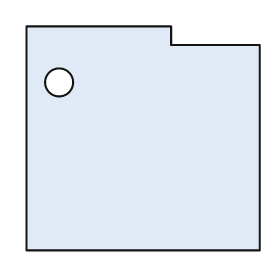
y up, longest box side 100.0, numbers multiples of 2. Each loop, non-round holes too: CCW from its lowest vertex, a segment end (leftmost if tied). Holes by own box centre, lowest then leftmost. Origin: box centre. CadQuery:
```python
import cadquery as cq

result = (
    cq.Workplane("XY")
    .moveTo(-50.0, -48.0)
    .lineTo(50.0, -48.0)
    .lineTo(50.0, 40.0)
    .lineTo(12.0, 40.0)
    .lineTo(12.0, 48.0)
    .lineTo(-50.0, 48.0)
    .close()
    .moveTo(-36.0, 24.0)
    .circle(6.0)
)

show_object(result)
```